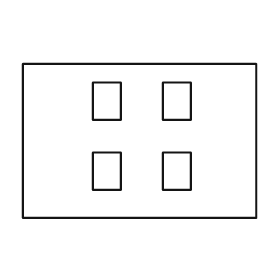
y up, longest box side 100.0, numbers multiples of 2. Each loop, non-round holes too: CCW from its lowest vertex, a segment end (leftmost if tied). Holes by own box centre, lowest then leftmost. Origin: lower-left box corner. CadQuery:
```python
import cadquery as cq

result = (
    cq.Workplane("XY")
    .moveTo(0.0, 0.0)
    .lineTo(100.0, 0.0)
    .lineTo(100.0, 66.0)
    .lineTo(0.0, 66.0)
    .close()
    .moveTo(30.0, 12.0)
    .lineTo(42.0, 12.0)
    .lineTo(42.0, 28.0)
    .lineTo(30.0, 28.0)
    .close()
    .moveTo(60.0, 12.0)
    .lineTo(72.0, 12.0)
    .lineTo(72.0, 28.0)
    .lineTo(60.0, 28.0)
    .close()
    .moveTo(30.0, 42.0)
    .lineTo(42.0, 42.0)
    .lineTo(42.0, 58.0)
    .lineTo(30.0, 58.0)
    .close()
    .moveTo(60.0, 42.0)
    .lineTo(72.0, 42.0)
    .lineTo(72.0, 58.0)
    .lineTo(60.0, 58.0)
    .close()
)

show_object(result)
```